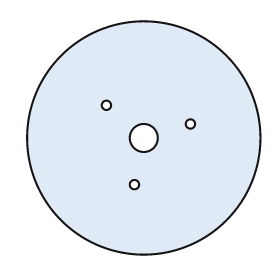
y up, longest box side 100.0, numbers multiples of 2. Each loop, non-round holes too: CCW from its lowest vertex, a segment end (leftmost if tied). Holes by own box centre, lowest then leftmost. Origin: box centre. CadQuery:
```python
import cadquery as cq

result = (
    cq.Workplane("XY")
    .moveTo(0.0, 0.0)
    .circle(50.0)
    .moveTo(-4.0, -20.0)
    .circle(2.0)
    .moveTo(0.0, 0.0)
    .circle(6.0)
    .moveTo(20.0, 6.0)
    .circle(2.0)
    .moveTo(-16.0, 14.0)
    .circle(2.0)
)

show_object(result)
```